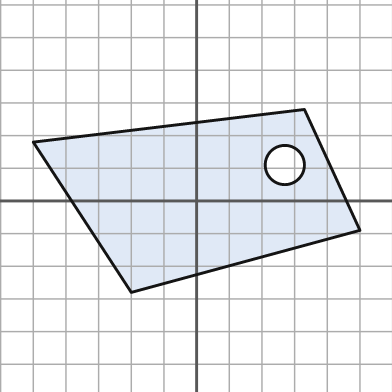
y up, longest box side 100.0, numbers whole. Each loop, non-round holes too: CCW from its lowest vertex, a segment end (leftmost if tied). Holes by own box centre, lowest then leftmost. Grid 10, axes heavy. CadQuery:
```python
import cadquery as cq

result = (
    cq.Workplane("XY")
    .moveTo(-20.0, -28.0)
    .lineTo(50.0, -9.0)
    .lineTo(33.0, 28.0)
    .lineTo(-50.0, 18.0)
    .close()
    .moveTo(27.0, 11.0)
    .circle(6.0)
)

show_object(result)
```